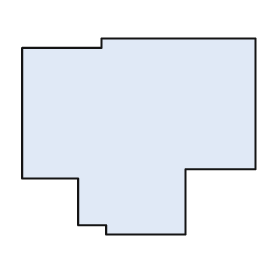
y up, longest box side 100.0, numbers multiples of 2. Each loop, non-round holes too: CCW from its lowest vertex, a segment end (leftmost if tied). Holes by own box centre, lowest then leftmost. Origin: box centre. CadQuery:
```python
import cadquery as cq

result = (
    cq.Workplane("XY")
    .moveTo(-14.0, -42.0)
    .lineTo(20.0, -42.0)
    .lineTo(20.0, -14.0)
    .lineTo(50.0, -14.0)
    .lineTo(50.0, 42.0)
    .lineTo(-16.0, 42.0)
    .lineTo(-16.0, 38.0)
    .lineTo(-50.0, 38.0)
    .lineTo(-50.0, -18.0)
    .lineTo(-26.0, -18.0)
    .lineTo(-26.0, -38.0)
    .lineTo(-14.0, -38.0)
    .close()
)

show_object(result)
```